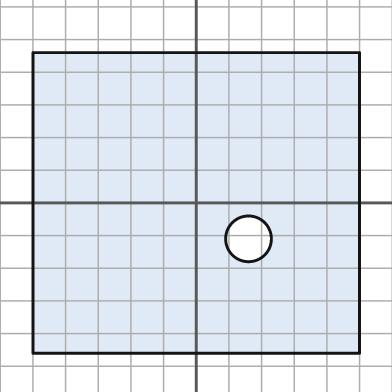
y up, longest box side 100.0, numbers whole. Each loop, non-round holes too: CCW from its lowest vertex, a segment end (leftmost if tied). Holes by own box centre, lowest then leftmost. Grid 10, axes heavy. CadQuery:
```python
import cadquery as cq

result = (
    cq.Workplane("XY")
    .moveTo(-50.0, -46.0)
    .lineTo(50.0, -46.0)
    .lineTo(50.0, 46.0)
    .lineTo(-50.0, 46.0)
    .close()
    .moveTo(16.0, -11.0)
    .circle(7.0)
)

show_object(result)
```